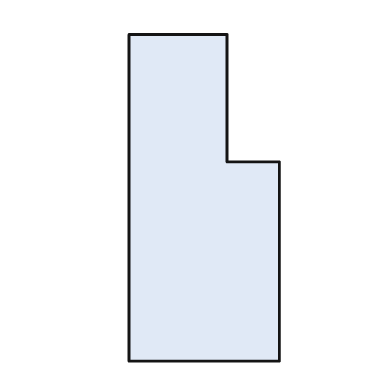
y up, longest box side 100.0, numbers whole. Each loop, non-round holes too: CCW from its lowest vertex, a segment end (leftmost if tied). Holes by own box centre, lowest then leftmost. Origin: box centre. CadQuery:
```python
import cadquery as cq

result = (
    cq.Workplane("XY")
    .moveTo(-23.0, -50.0)
    .lineTo(23.0, -50.0)
    .lineTo(23.0, 11.0)
    .lineTo(7.0, 11.0)
    .lineTo(7.0, 50.0)
    .lineTo(-23.0, 50.0)
    .close()
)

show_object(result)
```